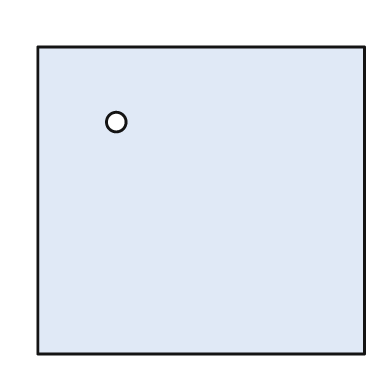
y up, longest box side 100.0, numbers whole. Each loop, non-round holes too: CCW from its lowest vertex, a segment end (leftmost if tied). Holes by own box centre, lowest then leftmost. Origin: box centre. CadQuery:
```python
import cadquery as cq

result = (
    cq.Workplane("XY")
    .moveTo(-50.0, -47.0)
    .lineTo(50.0, -47.0)
    .lineTo(50.0, 47.0)
    .lineTo(-50.0, 47.0)
    .close()
    .moveTo(-26.0, 24.0)
    .circle(3.0)
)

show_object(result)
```